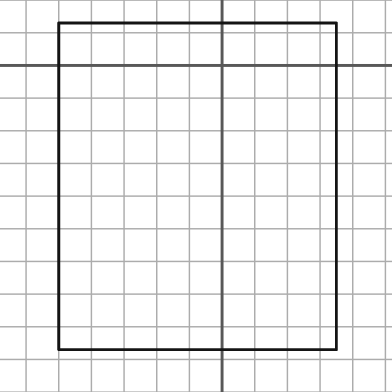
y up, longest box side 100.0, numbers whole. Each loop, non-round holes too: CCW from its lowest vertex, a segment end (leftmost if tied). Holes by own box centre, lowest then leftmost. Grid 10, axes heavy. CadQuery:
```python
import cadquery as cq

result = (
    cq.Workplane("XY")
    .moveTo(-50.0, -87.0)
    .lineTo(35.0, -87.0)
    .lineTo(35.0, 13.0)
    .lineTo(-50.0, 13.0)
    .close()
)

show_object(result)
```